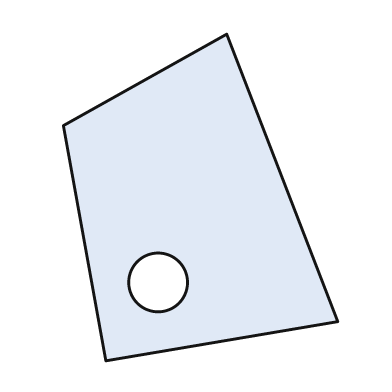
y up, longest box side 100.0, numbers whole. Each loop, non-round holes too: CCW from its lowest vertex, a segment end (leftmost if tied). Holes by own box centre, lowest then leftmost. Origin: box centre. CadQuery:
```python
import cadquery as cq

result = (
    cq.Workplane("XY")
    .moveTo(-29.0, -50.0)
    .lineTo(42.0, -38.0)
    .lineTo(8.0, 50.0)
    .lineTo(-42.0, 22.0)
    .close()
    .moveTo(-13.0, -26.0)
    .circle(9.0)
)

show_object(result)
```